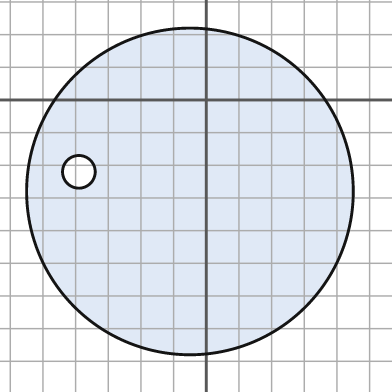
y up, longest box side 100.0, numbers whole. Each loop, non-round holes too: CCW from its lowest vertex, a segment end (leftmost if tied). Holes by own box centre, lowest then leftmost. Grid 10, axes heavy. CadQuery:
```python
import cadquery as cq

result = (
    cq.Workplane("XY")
    .moveTo(-5.0, -28.0)
    .circle(50.0)
    .moveTo(-39.0, -22.0)
    .circle(5.0)
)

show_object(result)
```